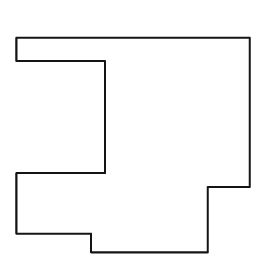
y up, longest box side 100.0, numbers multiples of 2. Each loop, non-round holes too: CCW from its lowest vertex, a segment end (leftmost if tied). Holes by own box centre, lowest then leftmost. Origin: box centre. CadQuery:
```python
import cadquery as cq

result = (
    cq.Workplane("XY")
    .moveTo(-18.0, -46.0)
    .lineTo(32.0, -46.0)
    .lineTo(32.0, -18.0)
    .lineTo(50.0, -18.0)
    .lineTo(50.0, 46.0)
    .lineTo(-50.0, 46.0)
    .lineTo(-50.0, 36.0)
    .lineTo(-12.0, 36.0)
    .lineTo(-12.0, -12.0)
    .lineTo(-50.0, -12.0)
    .lineTo(-50.0, -38.0)
    .lineTo(-18.0, -38.0)
    .close()
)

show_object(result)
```